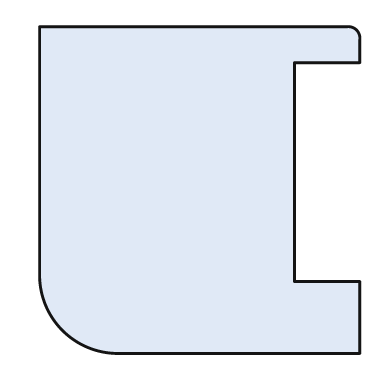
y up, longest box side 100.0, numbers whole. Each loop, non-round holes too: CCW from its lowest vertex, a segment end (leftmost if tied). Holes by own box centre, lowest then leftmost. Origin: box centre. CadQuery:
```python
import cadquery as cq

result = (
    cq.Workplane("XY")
    .moveTo(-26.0, -50.0)
    .lineTo(49.0, -50.0)
    .lineTo(49.0, -28.0)
    .lineTo(29.0, -28.0)
    .lineTo(29.0, 39.0)
    .lineTo(49.0, 39.0)
    .lineTo(49.0, 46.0)
    .threePointArc((48.0, 49.0), (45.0, 50.0))
    .lineTo(-49.0, 50.0)
    .lineTo(-49.0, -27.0)
    .threePointArc((-42.0, -43.0), (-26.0, -50.0))
    .close()
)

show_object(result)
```